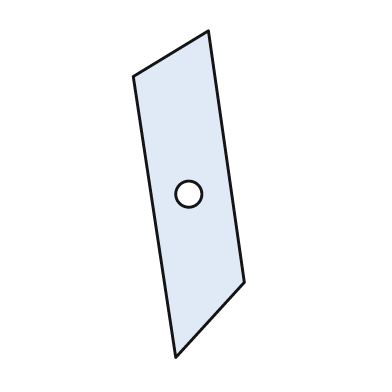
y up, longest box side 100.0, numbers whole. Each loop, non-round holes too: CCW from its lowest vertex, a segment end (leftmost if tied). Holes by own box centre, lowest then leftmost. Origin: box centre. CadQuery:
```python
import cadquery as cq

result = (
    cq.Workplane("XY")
    .moveTo(-4.0, -50.0)
    .lineTo(17.0, -27.0)
    .lineTo(6.0, 50.0)
    .lineTo(-17.0, 36.0)
    .close()
    .moveTo(0.0, 0.0)
    .circle(4.0)
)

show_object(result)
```